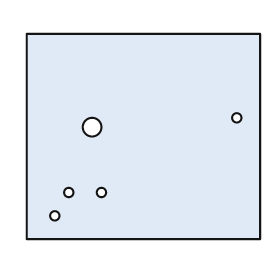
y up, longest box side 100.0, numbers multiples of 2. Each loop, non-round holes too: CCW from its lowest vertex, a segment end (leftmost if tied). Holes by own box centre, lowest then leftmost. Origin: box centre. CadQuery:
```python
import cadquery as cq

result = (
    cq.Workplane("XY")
    .moveTo(-50.0, -44.0)
    .lineTo(50.0, -44.0)
    .lineTo(50.0, 44.0)
    .lineTo(-50.0, 44.0)
    .close()
    .moveTo(-38.0, -34.0)
    .circle(2.0)
    .moveTo(-32.0, -24.0)
    .circle(2.0)
    .moveTo(-18.0, -24.0)
    .circle(2.0)
    .moveTo(-22.0, 4.0)
    .circle(4.0)
    .moveTo(40.0, 8.0)
    .circle(2.0)
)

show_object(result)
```